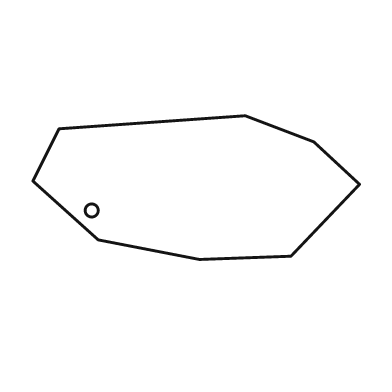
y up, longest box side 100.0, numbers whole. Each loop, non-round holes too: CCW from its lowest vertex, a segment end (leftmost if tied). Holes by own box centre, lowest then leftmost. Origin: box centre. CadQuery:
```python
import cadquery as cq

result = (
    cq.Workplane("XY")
    .moveTo(1.0, -22.0)
    .lineTo(29.0, -21.0)
    .lineTo(50.0, 1.0)
    .lineTo(36.0, 14.0)
    .lineTo(15.0, 22.0)
    .lineTo(-42.0, 18.0)
    .lineTo(-50.0, 2.0)
    .lineTo(-30.0, -16.0)
    .close()
    .moveTo(-32.0, -7.0)
    .circle(2.0)
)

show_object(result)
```